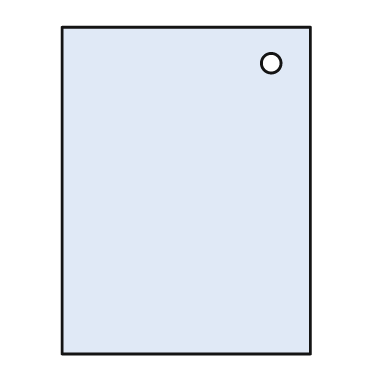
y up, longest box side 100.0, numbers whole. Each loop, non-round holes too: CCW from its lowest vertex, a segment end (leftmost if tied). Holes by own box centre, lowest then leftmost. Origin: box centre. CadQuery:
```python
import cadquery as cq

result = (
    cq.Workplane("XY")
    .moveTo(-38.0, -50.0)
    .lineTo(38.0, -50.0)
    .lineTo(38.0, 50.0)
    .lineTo(-38.0, 50.0)
    .close()
    .moveTo(26.0, 39.0)
    .circle(3.0)
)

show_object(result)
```